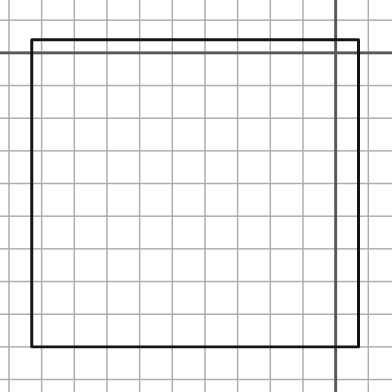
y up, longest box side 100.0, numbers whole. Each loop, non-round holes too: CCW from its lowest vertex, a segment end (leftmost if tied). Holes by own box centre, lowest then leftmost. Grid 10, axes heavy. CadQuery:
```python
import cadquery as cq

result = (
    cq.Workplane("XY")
    .moveTo(-93.0, -90.0)
    .lineTo(7.0, -90.0)
    .lineTo(7.0, 4.0)
    .lineTo(-93.0, 4.0)
    .close()
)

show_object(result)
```